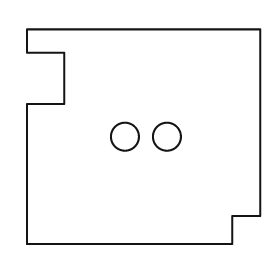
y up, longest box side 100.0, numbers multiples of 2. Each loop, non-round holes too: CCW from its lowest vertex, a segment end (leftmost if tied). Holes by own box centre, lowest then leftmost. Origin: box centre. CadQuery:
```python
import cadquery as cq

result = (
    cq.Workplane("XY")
    .moveTo(-50.0, -46.0)
    .lineTo(38.0, -46.0)
    .lineTo(38.0, -34.0)
    .lineTo(50.0, -34.0)
    .lineTo(50.0, 46.0)
    .lineTo(-50.0, 46.0)
    .lineTo(-50.0, 36.0)
    .lineTo(-34.0, 36.0)
    .lineTo(-34.0, 14.0)
    .lineTo(-50.0, 14.0)
    .close()
    .moveTo(-8.0, 0.0)
    .circle(6.0)
    .moveTo(10.0, 0.0)
    .circle(6.0)
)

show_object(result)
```